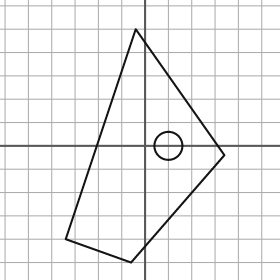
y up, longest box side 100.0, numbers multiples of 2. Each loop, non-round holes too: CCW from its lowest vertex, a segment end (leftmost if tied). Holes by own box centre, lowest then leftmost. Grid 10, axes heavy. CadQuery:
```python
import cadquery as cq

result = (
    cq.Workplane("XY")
    .moveTo(-6.0, -50.0)
    .lineTo(34.0, -4.0)
    .lineTo(-4.0, 50.0)
    .lineTo(-34.0, -40.0)
    .close()
    .moveTo(10.0, 0.0)
    .circle(6.0)
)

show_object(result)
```